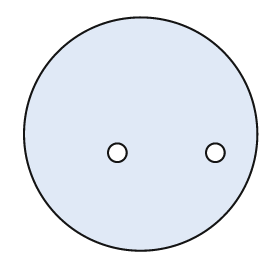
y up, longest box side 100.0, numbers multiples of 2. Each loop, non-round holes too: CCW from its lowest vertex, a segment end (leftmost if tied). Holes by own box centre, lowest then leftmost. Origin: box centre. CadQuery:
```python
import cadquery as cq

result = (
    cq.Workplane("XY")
    .moveTo(0.0, 0.0)
    .circle(50.0)
    .moveTo(-10.0, -8.0)
    .circle(4.0)
    .moveTo(32.0, -8.0)
    .circle(4.0)
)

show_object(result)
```